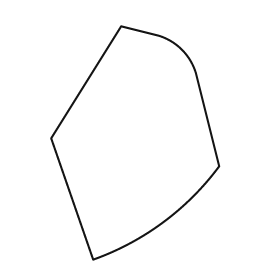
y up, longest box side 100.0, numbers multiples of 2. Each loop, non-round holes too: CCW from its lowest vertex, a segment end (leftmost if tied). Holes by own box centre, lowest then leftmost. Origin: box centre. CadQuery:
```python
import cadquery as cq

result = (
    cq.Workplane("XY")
    .moveTo(-18.0, -50.0)
    .threePointArc((12.0, -34.0), (36.0, -10.0))
    .lineTo(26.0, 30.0)
    .threePointArc((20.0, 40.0), (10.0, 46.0))
    .lineTo(-6.0, 50.0)
    .lineTo(-36.0, 2.0)
    .close()
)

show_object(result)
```